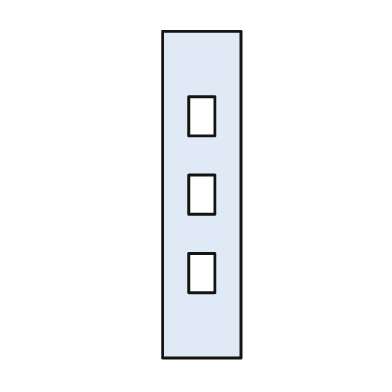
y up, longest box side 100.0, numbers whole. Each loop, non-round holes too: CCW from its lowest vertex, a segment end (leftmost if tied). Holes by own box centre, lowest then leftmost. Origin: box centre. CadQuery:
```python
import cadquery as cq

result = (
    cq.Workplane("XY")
    .moveTo(-12.0, -50.0)
    .lineTo(12.0, -50.0)
    .lineTo(12.0, 50.0)
    .lineTo(-12.0, 50.0)
    .close()
    .moveTo(-4.0, -30.0)
    .lineTo(4.0, -30.0)
    .lineTo(4.0, -18.0)
    .lineTo(-4.0, -18.0)
    .close()
    .moveTo(-4.0, -6.0)
    .lineTo(4.0, -6.0)
    .lineTo(4.0, 6.0)
    .lineTo(-4.0, 6.0)
    .close()
    .moveTo(-4.0, 18.0)
    .lineTo(4.0, 18.0)
    .lineTo(4.0, 30.0)
    .lineTo(-4.0, 30.0)
    .close()
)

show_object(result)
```